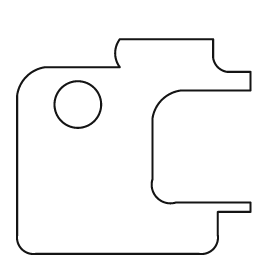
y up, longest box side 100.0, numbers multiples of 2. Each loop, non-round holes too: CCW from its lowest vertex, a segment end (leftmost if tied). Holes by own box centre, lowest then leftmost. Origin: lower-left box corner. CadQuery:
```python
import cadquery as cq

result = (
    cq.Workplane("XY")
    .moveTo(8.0, 0.0)
    .lineTo(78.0, 0.0)
    .threePointArc((84.0, 2.0), (86.0, 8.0))
    .lineTo(86.0, 18.0)
    .lineTo(100.0, 18.0)
    .lineTo(100.0, 22.0)
    .lineTo(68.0, 22.0)
    .threePointArc((60.0, 24.0), (58.0, 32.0))
    .lineTo(58.0, 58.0)
    .threePointArc((62.0, 66.0), (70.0, 70.0))
    .lineTo(100.0, 70.0)
    .lineTo(100.0, 78.0)
    .lineTo(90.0, 78.0)
    .threePointArc((86.0, 80.0), (84.0, 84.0))
    .lineTo(84.0, 92.0)
    .lineTo(44.0, 92.0)
    .threePointArc((42.0, 86.0), (44.0, 80.0))
    .lineTo(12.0, 80.0)
    .threePointArc((4.0, 76.0), (0.0, 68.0))
    .lineTo(0.0, 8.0)
    .threePointArc((2.0, 2.0), (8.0, 0.0))
    .close()
    .moveTo(26.0, 64.0)
    .circle(10.0)
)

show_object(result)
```